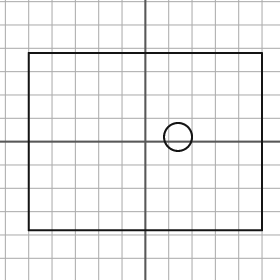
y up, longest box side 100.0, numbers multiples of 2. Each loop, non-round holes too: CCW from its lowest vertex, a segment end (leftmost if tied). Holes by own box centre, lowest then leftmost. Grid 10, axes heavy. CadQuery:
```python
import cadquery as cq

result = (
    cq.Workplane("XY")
    .moveTo(-50.0, -38.0)
    .lineTo(50.0, -38.0)
    .lineTo(50.0, 38.0)
    .lineTo(-50.0, 38.0)
    .close()
    .moveTo(14.0, 2.0)
    .circle(6.0)
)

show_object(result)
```